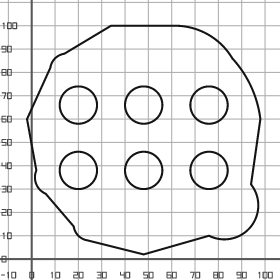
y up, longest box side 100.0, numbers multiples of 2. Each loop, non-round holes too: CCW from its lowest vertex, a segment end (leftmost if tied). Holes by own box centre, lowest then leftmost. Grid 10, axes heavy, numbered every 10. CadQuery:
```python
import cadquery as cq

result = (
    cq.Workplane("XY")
    .moveTo(48.0, 2.0)
    .lineTo(76.0, 10.0)
    .threePointArc((94.0, 14.0), (94.0, 32.0))
    .lineTo(98.0, 60.0)
    .threePointArc((94.0, 74.0), (86.0, 86.0))
    .threePointArc((76.0, 96.0), (62.0, 100.0))
    .lineTo(34.0, 100.0)
    .lineTo(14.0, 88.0)
    .threePointArc((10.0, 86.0), (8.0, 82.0))
    .lineTo(-2.0, 60.0)
    .lineTo(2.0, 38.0)
    .threePointArc((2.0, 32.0), (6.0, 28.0))
    .lineTo(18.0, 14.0)
    .threePointArc((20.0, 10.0), (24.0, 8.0))
    .close()
    .moveTo(20.0, 38.0)
    .circle(8.0)
    .moveTo(48.0, 38.0)
    .circle(8.0)
    .moveTo(76.0, 38.0)
    .circle(8.0)
    .moveTo(20.0, 66.0)
    .circle(8.0)
    .moveTo(48.0, 66.0)
    .circle(8.0)
    .moveTo(76.0, 66.0)
    .circle(8.0)
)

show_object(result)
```